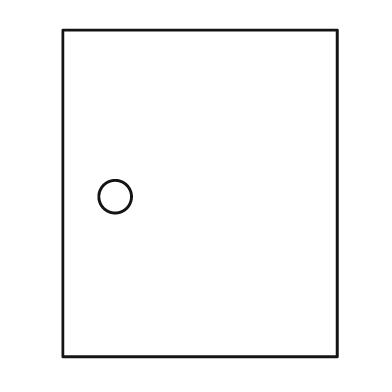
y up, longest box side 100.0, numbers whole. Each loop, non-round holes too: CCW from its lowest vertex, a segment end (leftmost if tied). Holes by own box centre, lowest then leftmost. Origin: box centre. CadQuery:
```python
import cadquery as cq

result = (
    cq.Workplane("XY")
    .moveTo(-42.0, -50.0)
    .lineTo(42.0, -50.0)
    .lineTo(42.0, 50.0)
    .lineTo(-42.0, 50.0)
    .close()
    .moveTo(-26.0, -1.0)
    .circle(5.0)
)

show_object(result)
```